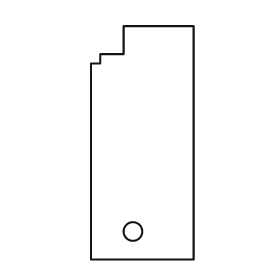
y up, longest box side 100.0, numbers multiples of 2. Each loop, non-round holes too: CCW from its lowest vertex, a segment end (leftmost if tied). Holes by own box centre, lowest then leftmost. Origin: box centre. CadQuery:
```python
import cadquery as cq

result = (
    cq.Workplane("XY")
    .moveTo(-22.0, -50.0)
    .lineTo(22.0, -50.0)
    .lineTo(22.0, 50.0)
    .lineTo(-8.0, 50.0)
    .lineTo(-8.0, 38.0)
    .lineTo(-18.0, 38.0)
    .lineTo(-18.0, 34.0)
    .lineTo(-22.0, 34.0)
    .close()
    .moveTo(-4.0, -38.0)
    .circle(4.0)
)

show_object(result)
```